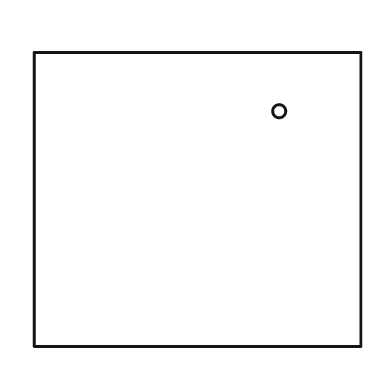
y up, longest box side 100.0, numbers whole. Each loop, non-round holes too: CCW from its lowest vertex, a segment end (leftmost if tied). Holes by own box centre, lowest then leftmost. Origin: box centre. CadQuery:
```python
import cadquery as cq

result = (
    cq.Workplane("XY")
    .moveTo(-50.0, -45.0)
    .lineTo(50.0, -45.0)
    .lineTo(50.0, 45.0)
    .lineTo(-50.0, 45.0)
    .close()
    .moveTo(25.0, 27.0)
    .circle(2.0)
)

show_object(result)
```